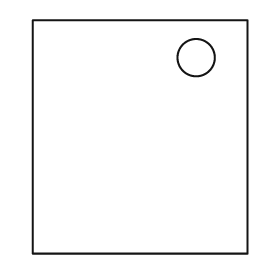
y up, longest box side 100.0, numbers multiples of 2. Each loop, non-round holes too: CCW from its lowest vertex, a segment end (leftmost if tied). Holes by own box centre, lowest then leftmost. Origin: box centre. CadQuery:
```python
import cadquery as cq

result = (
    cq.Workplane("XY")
    .moveTo(-46.0, -50.0)
    .lineTo(46.0, -50.0)
    .lineTo(46.0, 50.0)
    .lineTo(-46.0, 50.0)
    .close()
    .moveTo(24.0, 34.0)
    .circle(8.0)
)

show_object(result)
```